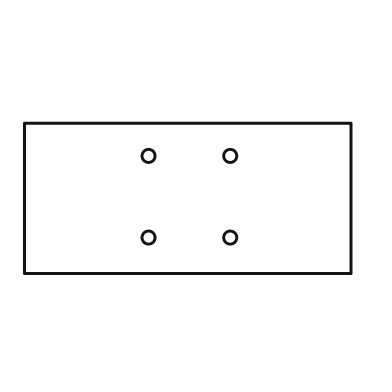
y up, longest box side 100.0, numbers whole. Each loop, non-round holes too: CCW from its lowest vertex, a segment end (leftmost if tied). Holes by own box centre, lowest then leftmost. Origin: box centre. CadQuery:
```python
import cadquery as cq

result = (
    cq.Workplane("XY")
    .moveTo(-50.0, -23.0)
    .lineTo(50.0, -23.0)
    .lineTo(50.0, 23.0)
    .lineTo(-50.0, 23.0)
    .close()
    .moveTo(-12.0, -12.0)
    .circle(2.0)
    .moveTo(13.0, -12.0)
    .circle(2.0)
    .moveTo(-12.0, 13.0)
    .circle(2.0)
    .moveTo(13.0, 13.0)
    .circle(2.0)
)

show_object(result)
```